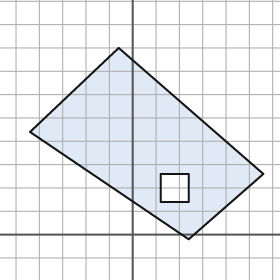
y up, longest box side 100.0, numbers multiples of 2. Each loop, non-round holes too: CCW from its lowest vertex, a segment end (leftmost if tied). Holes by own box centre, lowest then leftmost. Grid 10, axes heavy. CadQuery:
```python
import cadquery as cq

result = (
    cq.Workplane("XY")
    .moveTo(24.0, -2.0)
    .lineTo(56.0, 26.0)
    .lineTo(-6.0, 80.0)
    .lineTo(-44.0, 44.0)
    .close()
    .moveTo(12.0, 14.0)
    .lineTo(24.0, 14.0)
    .lineTo(24.0, 26.0)
    .lineTo(12.0, 26.0)
    .close()
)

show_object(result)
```